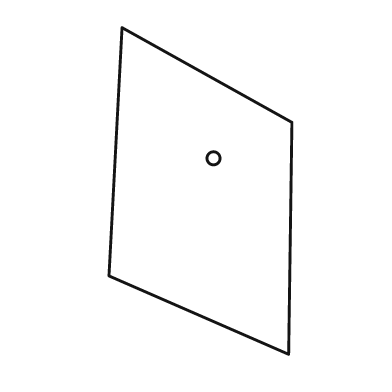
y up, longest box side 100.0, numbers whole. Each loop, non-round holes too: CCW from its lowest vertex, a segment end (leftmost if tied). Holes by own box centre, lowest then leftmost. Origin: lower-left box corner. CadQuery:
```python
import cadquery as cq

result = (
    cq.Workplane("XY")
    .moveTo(55.0, 0.0)
    .lineTo(56.0, 71.0)
    .lineTo(4.0, 100.0)
    .lineTo(0.0, 24.0)
    .close()
    .moveTo(32.0, 60.0)
    .circle(2.0)
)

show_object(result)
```